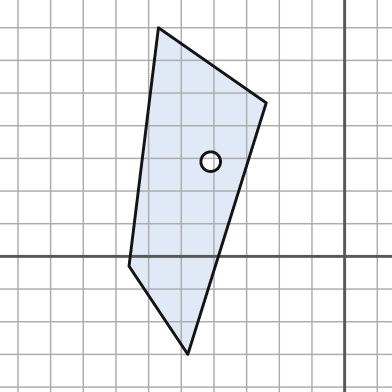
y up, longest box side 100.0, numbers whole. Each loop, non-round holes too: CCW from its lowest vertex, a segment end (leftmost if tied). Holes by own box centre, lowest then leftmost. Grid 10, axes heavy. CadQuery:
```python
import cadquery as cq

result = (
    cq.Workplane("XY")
    .moveTo(-48.0, -30.0)
    .lineTo(-24.0, 47.0)
    .lineTo(-57.0, 70.0)
    .lineTo(-66.0, -3.0)
    .close()
    .moveTo(-41.0, 29.0)
    .circle(3.0)
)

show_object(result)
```